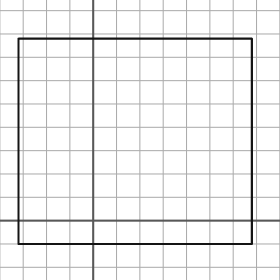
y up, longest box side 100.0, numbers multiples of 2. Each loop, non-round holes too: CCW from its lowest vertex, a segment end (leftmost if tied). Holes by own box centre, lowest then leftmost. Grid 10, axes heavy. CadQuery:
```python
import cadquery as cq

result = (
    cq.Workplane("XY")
    .moveTo(-32.0, -10.0)
    .lineTo(68.0, -10.0)
    .lineTo(68.0, 78.0)
    .lineTo(-32.0, 78.0)
    .close()
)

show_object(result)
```